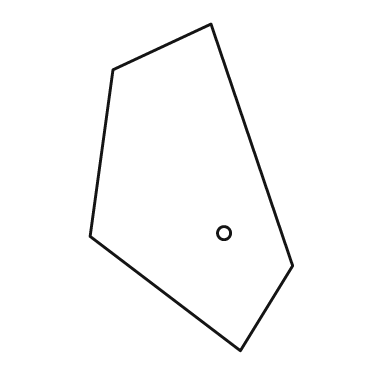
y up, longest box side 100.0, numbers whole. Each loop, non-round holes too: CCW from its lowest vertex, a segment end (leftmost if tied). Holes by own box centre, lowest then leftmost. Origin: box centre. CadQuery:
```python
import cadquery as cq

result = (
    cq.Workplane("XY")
    .moveTo(15.0, -50.0)
    .lineTo(31.0, -24.0)
    .lineTo(6.0, 50.0)
    .lineTo(-24.0, 36.0)
    .lineTo(-31.0, -15.0)
    .close()
    .moveTo(10.0, -14.0)
    .circle(2.0)
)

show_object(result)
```